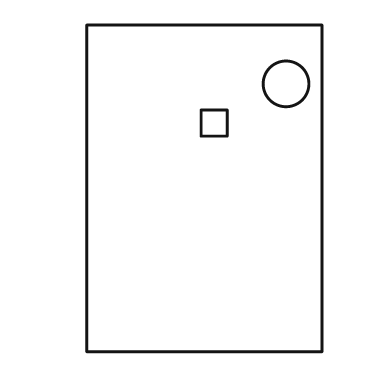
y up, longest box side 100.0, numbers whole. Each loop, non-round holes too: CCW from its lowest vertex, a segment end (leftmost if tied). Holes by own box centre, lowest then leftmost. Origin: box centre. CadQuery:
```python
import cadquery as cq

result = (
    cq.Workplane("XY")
    .moveTo(-36.0, -50.0)
    .lineTo(36.0, -50.0)
    .lineTo(36.0, 50.0)
    .lineTo(-36.0, 50.0)
    .close()
    .moveTo(-1.0, 16.0)
    .lineTo(7.0, 16.0)
    .lineTo(7.0, 24.0)
    .lineTo(-1.0, 24.0)
    .close()
    .moveTo(25.0, 32.0)
    .circle(7.0)
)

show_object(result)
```